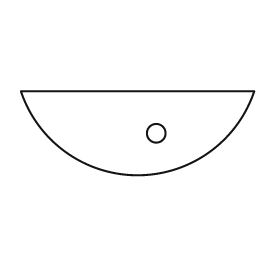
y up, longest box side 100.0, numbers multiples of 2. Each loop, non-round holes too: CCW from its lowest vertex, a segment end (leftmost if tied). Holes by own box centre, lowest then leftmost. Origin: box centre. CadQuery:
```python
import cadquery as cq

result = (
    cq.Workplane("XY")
    .moveTo(-50.0, 18.0)
    .threePointArc((0.0, -18.0), (50.0, 18.0))
    .close()
    .moveTo(8.0, 0.0)
    .circle(4.0)
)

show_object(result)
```